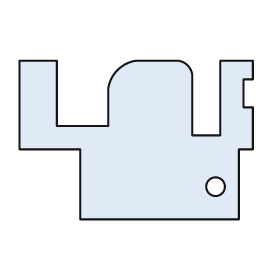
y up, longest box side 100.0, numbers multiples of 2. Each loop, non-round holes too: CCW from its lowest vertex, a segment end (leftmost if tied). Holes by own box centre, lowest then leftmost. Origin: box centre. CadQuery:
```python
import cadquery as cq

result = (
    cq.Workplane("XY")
    .moveTo(-24.0, -34.0)
    .lineTo(44.0, -34.0)
    .lineTo(44.0, -4.0)
    .lineTo(50.0, -4.0)
    .lineTo(50.0, 14.0)
    .lineTo(46.0, 14.0)
    .lineTo(46.0, 26.0)
    .lineTo(50.0, 26.0)
    .lineTo(50.0, 34.0)
    .lineTo(36.0, 34.0)
    .lineTo(36.0, 2.0)
    .lineTo(24.0, 2.0)
    .lineTo(24.0, 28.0)
    .threePointArc((22.0, 32.0), (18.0, 34.0))
    .lineTo(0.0, 34.0)
    .threePointArc((-8.0, 30.0), (-12.0, 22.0))
    .lineTo(-12.0, 6.0)
    .lineTo(-34.0, 6.0)
    .lineTo(-34.0, 34.0)
    .lineTo(-50.0, 34.0)
    .lineTo(-50.0, -4.0)
    .lineTo(-24.0, -4.0)
    .close()
    .moveTo(34.0, -20.0)
    .circle(4.0)
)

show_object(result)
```